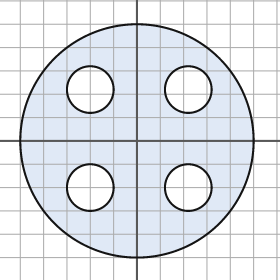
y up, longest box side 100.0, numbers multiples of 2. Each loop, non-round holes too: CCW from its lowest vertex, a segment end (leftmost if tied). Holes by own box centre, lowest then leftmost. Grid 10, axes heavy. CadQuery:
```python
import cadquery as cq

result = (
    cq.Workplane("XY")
    .moveTo(0.0, 0.0)
    .circle(50.0)
    .moveTo(-20.0, -20.0)
    .circle(10.0)
    .moveTo(22.0, -20.0)
    .circle(10.0)
    .moveTo(-20.0, 22.0)
    .circle(10.0)
    .moveTo(22.0, 22.0)
    .circle(10.0)
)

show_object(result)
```